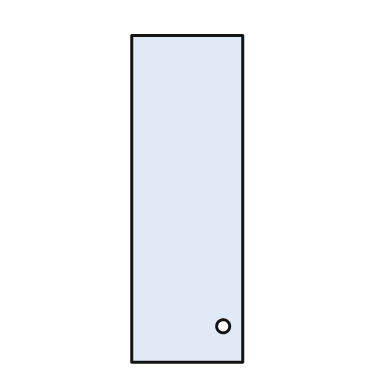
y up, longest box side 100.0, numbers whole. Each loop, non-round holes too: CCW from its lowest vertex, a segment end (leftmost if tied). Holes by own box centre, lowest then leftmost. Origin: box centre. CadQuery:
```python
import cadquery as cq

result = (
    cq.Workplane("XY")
    .moveTo(-17.0, -50.0)
    .lineTo(17.0, -50.0)
    .lineTo(17.0, 50.0)
    .lineTo(-17.0, 50.0)
    .close()
    .moveTo(11.0, -39.0)
    .circle(2.0)
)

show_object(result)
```